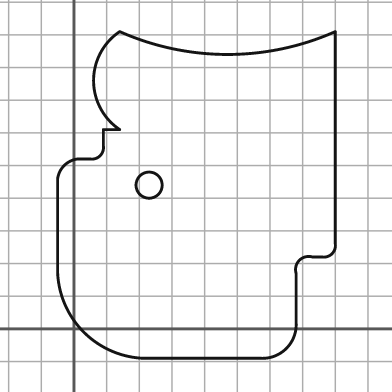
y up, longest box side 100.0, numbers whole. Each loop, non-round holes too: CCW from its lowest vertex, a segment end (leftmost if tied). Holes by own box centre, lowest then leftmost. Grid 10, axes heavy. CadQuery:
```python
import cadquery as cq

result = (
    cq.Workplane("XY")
    .moveTo(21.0, -9.0)
    .lineTo(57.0, -9.0)
    .threePointArc((65.0, -6.0), (68.0, 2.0))
    .lineTo(68.0, 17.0)
    .threePointArc((69.0, 21.0), (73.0, 22.0))
    .lineTo(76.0, 22.0)
    .threePointArc((79.0, 23.0), (80.0, 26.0))
    .lineTo(80.0, 91.0)
    .threePointArc((47.0, 84.0), (14.0, 91.0))
    .threePointArc((6.0, 76.0), (14.0, 61.0))
    .lineTo(9.0, 61.0)
    .lineTo(9.0, 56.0)
    .threePointArc((8.0, 53.0), (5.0, 52.0))
    .lineTo(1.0, 52.0)
    .threePointArc((-3.0, 50.0), (-5.0, 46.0))
    .lineTo(-5.0, 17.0)
    .threePointArc((3.0, -1.0), (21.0, -9.0))
    .close()
    .moveTo(23.0, 44.0)
    .circle(4.0)
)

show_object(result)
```